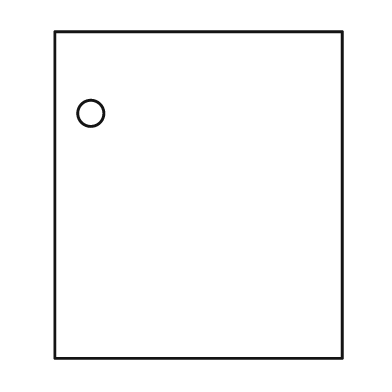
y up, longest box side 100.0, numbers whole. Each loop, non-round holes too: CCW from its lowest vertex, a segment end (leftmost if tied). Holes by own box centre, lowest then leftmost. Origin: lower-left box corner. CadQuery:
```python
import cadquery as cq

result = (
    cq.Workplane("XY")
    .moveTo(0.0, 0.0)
    .lineTo(88.0, 0.0)
    .lineTo(88.0, 100.0)
    .lineTo(0.0, 100.0)
    .close()
    .moveTo(11.0, 75.0)
    .circle(4.0)
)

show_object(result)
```